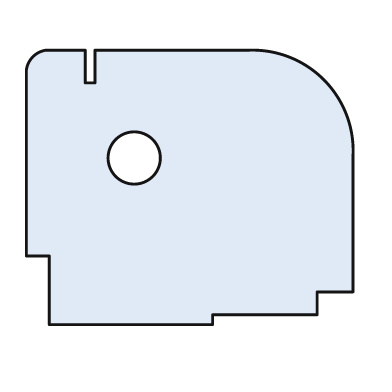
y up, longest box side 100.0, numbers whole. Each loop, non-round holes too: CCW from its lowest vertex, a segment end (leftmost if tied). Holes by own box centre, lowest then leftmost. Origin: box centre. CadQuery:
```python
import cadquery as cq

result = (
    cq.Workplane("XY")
    .moveTo(-43.0, -42.0)
    .lineTo(7.0, -42.0)
    .lineTo(7.0, -39.0)
    .lineTo(39.0, -39.0)
    .lineTo(39.0, -32.0)
    .lineTo(50.0, -32.0)
    .lineTo(50.0, 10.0)
    .threePointArc((41.0, 33.0), (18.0, 42.0))
    .lineTo(-29.0, 42.0)
    .lineTo(-29.0, 32.0)
    .lineTo(-32.0, 32.0)
    .lineTo(-32.0, 42.0)
    .lineTo(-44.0, 42.0)
    .threePointArc((-48.0, 40.0), (-50.0, 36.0))
    .lineTo(-50.0, -21.0)
    .lineTo(-43.0, -21.0)
    .close()
    .moveTo(-17.0, 9.0)
    .circle(8.0)
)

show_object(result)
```